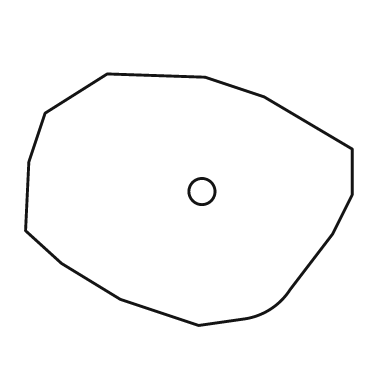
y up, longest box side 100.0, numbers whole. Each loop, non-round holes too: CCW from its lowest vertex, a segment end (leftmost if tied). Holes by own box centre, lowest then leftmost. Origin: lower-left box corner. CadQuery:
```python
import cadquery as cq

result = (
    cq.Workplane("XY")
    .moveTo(53.0, 0.0)
    .lineTo(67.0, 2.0)
    .threePointArc((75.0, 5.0), (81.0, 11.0))
    .lineTo(94.0, 28.0)
    .lineTo(100.0, 40.0)
    .lineTo(100.0, 54.0)
    .lineTo(73.0, 70.0)
    .lineTo(55.0, 76.0)
    .lineTo(25.0, 77.0)
    .lineTo(6.0, 65.0)
    .lineTo(1.0, 50.0)
    .lineTo(0.0, 29.0)
    .lineTo(11.0, 19.0)
    .lineTo(29.0, 8.0)
    .close()
    .moveTo(54.0, 41.0)
    .circle(4.0)
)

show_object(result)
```